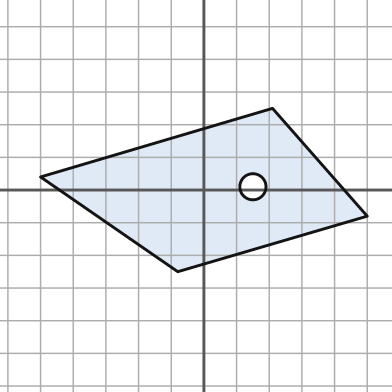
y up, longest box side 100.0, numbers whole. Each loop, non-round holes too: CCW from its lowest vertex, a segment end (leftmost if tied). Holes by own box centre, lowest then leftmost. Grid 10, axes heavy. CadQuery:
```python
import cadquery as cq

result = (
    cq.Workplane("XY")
    .moveTo(-8.0, -25.0)
    .lineTo(50.0, -8.0)
    .lineTo(21.0, 25.0)
    .lineTo(-50.0, 4.0)
    .close()
    .moveTo(15.0, 1.0)
    .circle(4.0)
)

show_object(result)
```